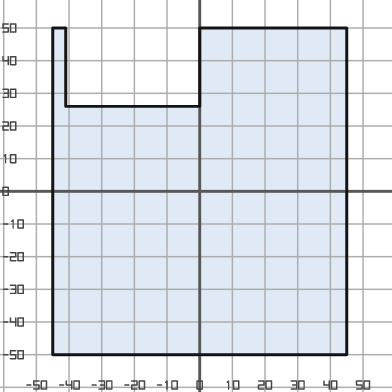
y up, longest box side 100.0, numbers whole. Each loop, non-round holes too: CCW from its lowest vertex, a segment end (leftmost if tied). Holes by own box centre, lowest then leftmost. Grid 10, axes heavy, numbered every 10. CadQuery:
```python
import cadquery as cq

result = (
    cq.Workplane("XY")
    .moveTo(-45.0, -50.0)
    .lineTo(45.0, -50.0)
    .lineTo(45.0, 50.0)
    .lineTo(0.0, 50.0)
    .lineTo(0.0, 26.0)
    .lineTo(-41.0, 26.0)
    .lineTo(-41.0, 50.0)
    .lineTo(-45.0, 50.0)
    .close()
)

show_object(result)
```